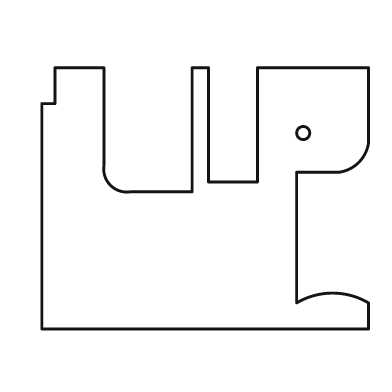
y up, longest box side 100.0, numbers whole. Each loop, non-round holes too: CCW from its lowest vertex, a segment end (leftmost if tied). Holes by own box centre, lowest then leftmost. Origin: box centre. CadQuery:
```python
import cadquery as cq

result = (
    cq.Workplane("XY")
    .moveTo(-50.0, -40.0)
    .lineTo(50.0, -40.0)
    .lineTo(50.0, -32.0)
    .threePointArc((39.0, -29.0), (28.0, -32.0))
    .lineTo(28.0, 8.0)
    .lineTo(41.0, 8.0)
    .threePointArc((47.0, 11.0), (50.0, 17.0))
    .lineTo(50.0, 40.0)
    .lineTo(16.0, 40.0)
    .lineTo(16.0, 5.0)
    .lineTo(1.0, 5.0)
    .lineTo(1.0, 40.0)
    .lineTo(-4.0, 40.0)
    .lineTo(-4.0, 2.0)
    .lineTo(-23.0, 2.0)
    .threePointArc((-29.0, 4.0), (-31.0, 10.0))
    .lineTo(-31.0, 40.0)
    .lineTo(-46.0, 40.0)
    .lineTo(-46.0, 29.0)
    .lineTo(-50.0, 29.0)
    .close()
    .moveTo(30.0, 20.0)
    .circle(2.0)
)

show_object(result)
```